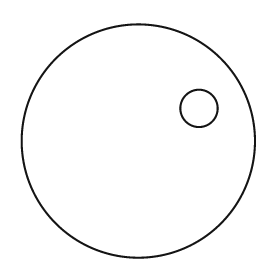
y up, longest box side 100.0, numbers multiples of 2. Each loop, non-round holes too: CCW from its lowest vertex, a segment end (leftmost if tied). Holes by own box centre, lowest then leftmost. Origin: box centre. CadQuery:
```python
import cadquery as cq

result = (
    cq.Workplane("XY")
    .moveTo(0.0, 0.0)
    .circle(50.0)
    .moveTo(26.0, 14.0)
    .circle(8.0)
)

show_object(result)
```